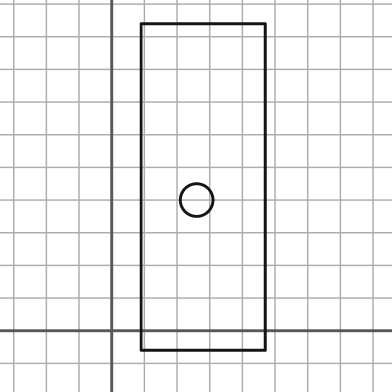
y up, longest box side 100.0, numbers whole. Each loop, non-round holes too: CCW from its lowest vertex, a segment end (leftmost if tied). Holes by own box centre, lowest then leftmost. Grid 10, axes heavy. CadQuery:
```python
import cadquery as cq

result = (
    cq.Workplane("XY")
    .moveTo(9.0, -6.0)
    .lineTo(47.0, -6.0)
    .lineTo(47.0, 94.0)
    .lineTo(9.0, 94.0)
    .close()
    .moveTo(26.0, 40.0)
    .circle(5.0)
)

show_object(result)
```